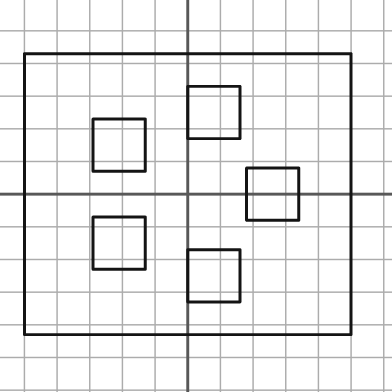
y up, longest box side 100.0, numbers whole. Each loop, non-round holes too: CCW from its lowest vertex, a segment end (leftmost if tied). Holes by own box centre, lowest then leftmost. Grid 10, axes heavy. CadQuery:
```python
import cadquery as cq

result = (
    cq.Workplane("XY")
    .moveTo(-50.0, -43.0)
    .lineTo(50.0, -43.0)
    .lineTo(50.0, 43.0)
    .lineTo(-50.0, 43.0)
    .close()
    .moveTo(0.0, -33.0)
    .lineTo(16.0, -33.0)
    .lineTo(16.0, -17.0)
    .lineTo(0.0, -17.0)
    .close()
    .moveTo(-29.0, -23.0)
    .lineTo(-13.0, -23.0)
    .lineTo(-13.0, -7.0)
    .lineTo(-29.0, -7.0)
    .close()
    .moveTo(18.0, -8.0)
    .lineTo(34.0, -8.0)
    .lineTo(34.0, 8.0)
    .lineTo(18.0, 8.0)
    .close()
    .moveTo(-29.0, 7.0)
    .lineTo(-13.0, 7.0)
    .lineTo(-13.0, 23.0)
    .lineTo(-29.0, 23.0)
    .close()
    .moveTo(0.0, 17.0)
    .lineTo(16.0, 17.0)
    .lineTo(16.0, 33.0)
    .lineTo(0.0, 33.0)
    .close()
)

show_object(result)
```